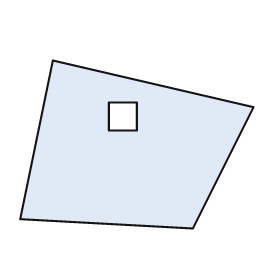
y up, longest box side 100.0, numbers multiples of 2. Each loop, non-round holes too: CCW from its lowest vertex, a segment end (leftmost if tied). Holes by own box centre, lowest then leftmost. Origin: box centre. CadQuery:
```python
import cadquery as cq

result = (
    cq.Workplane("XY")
    .moveTo(24.0, -36.0)
    .lineTo(50.0, 16.0)
    .lineTo(-36.0, 36.0)
    .lineTo(-50.0, -32.0)
    .close()
    .moveTo(-12.0, 6.0)
    .lineTo(0.0, 6.0)
    .lineTo(0.0, 18.0)
    .lineTo(-12.0, 18.0)
    .close()
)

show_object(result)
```